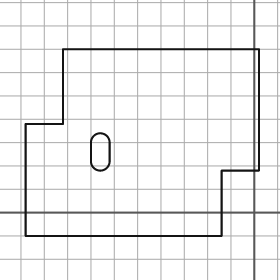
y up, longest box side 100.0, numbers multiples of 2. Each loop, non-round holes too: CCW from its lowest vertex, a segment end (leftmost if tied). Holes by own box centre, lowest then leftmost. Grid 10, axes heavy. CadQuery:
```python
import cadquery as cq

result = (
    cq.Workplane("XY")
    .moveTo(-98.0, -10.0)
    .lineTo(-14.0, -10.0)
    .lineTo(-14.0, 18.0)
    .lineTo(2.0, 18.0)
    .lineTo(2.0, 70.0)
    .lineTo(-82.0, 70.0)
    .lineTo(-82.0, 38.0)
    .lineTo(-98.0, 38.0)
    .close()
    .moveTo(-70.0, 22.0)
    .threePointArc((-66.0, 18.0), (-62.0, 22.0))
    .lineTo(-62.0, 30.0)
    .threePointArc((-66.0, 34.0), (-70.0, 30.0))
    .close()
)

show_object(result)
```